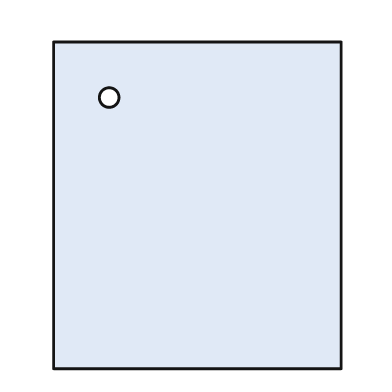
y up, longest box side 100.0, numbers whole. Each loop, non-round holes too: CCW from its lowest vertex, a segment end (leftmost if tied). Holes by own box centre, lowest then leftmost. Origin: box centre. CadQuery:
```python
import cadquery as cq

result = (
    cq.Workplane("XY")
    .moveTo(-44.0, -50.0)
    .lineTo(44.0, -50.0)
    .lineTo(44.0, 50.0)
    .lineTo(-44.0, 50.0)
    .close()
    .moveTo(-27.0, 33.0)
    .circle(3.0)
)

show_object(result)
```